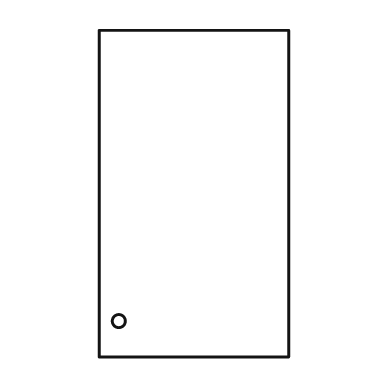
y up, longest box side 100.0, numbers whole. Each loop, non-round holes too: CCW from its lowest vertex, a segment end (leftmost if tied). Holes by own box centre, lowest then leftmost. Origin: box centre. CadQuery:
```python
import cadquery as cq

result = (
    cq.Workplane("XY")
    .moveTo(-29.0, -50.0)
    .lineTo(29.0, -50.0)
    .lineTo(29.0, 50.0)
    .lineTo(-29.0, 50.0)
    .close()
    .moveTo(-23.0, -39.0)
    .circle(2.0)
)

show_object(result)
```